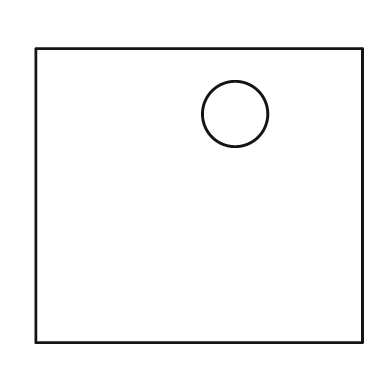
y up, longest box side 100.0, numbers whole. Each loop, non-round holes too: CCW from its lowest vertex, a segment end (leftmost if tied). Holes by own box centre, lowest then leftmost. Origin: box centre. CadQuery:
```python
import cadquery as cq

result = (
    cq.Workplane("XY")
    .moveTo(-50.0, -45.0)
    .lineTo(50.0, -45.0)
    .lineTo(50.0, 45.0)
    .lineTo(-50.0, 45.0)
    .close()
    .moveTo(11.0, 25.0)
    .circle(10.0)
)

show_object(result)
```